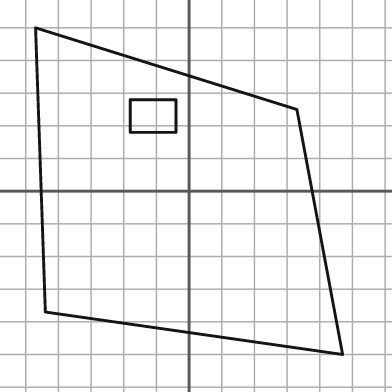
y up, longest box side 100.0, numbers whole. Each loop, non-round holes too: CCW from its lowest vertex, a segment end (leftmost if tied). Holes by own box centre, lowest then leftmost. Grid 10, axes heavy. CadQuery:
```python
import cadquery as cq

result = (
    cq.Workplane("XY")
    .moveTo(47.0, -50.0)
    .lineTo(33.0, 25.0)
    .lineTo(-47.0, 50.0)
    .lineTo(-44.0, -37.0)
    .close()
    .moveTo(-18.0, 18.0)
    .lineTo(-4.0, 18.0)
    .lineTo(-4.0, 28.0)
    .lineTo(-18.0, 28.0)
    .close()
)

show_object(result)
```